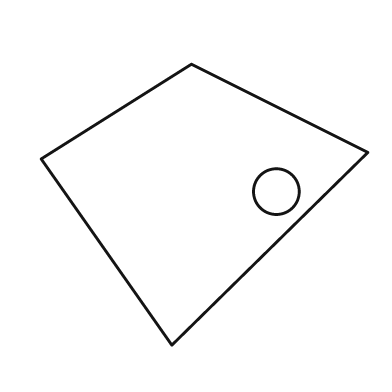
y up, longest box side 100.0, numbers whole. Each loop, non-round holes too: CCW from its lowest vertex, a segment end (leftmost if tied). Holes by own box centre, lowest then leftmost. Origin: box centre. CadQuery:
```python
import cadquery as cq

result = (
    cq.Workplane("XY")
    .moveTo(-10.0, -43.0)
    .lineTo(50.0, 16.0)
    .lineTo(-4.0, 43.0)
    .lineTo(-50.0, 14.0)
    .close()
    .moveTo(22.0, 4.0)
    .circle(7.0)
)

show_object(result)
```